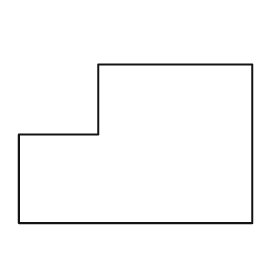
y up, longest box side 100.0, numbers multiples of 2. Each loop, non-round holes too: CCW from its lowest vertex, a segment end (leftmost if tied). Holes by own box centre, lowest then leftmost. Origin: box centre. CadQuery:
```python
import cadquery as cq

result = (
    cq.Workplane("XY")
    .moveTo(-50.0, -34.0)
    .lineTo(50.0, -34.0)
    .lineTo(50.0, 34.0)
    .lineTo(-16.0, 34.0)
    .lineTo(-16.0, 4.0)
    .lineTo(-50.0, 4.0)
    .close()
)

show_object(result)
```